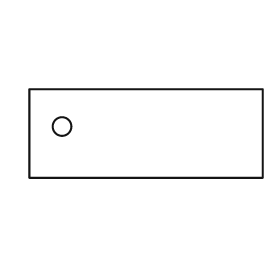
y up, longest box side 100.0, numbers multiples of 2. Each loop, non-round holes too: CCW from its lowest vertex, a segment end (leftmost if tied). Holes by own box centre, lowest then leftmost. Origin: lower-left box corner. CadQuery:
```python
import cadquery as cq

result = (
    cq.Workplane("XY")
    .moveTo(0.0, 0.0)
    .lineTo(100.0, 0.0)
    .lineTo(100.0, 38.0)
    .lineTo(0.0, 38.0)
    .close()
    .moveTo(14.0, 22.0)
    .circle(4.0)
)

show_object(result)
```